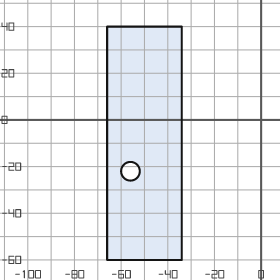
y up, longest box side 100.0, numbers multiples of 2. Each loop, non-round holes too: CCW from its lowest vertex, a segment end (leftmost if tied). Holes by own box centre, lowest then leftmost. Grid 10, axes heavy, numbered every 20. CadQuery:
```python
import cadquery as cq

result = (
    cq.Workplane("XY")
    .moveTo(-66.0, -60.0)
    .lineTo(-34.0, -60.0)
    .lineTo(-34.0, 40.0)
    .lineTo(-66.0, 40.0)
    .close()
    .moveTo(-56.0, -22.0)
    .circle(4.0)
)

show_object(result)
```